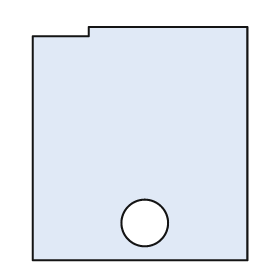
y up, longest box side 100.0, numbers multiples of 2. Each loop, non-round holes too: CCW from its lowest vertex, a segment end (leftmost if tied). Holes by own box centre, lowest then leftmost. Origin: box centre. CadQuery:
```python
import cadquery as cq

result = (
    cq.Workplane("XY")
    .moveTo(-46.0, -50.0)
    .lineTo(46.0, -50.0)
    .lineTo(46.0, 50.0)
    .lineTo(-22.0, 50.0)
    .lineTo(-22.0, 46.0)
    .lineTo(-46.0, 46.0)
    .close()
    .moveTo(2.0, -34.0)
    .circle(10.0)
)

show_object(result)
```